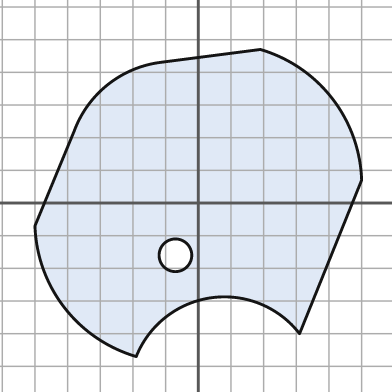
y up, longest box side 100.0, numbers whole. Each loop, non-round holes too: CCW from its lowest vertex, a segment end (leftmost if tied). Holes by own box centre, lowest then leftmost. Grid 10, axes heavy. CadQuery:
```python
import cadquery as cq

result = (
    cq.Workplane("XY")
    .moveTo(-19.0, -47.0)
    .threePointArc((4.0, -29.0), (31.0, -40.0))
    .lineTo(50.0, 7.0)
    .threePointArc((41.0, 32.0), (19.0, 47.0))
    .lineTo(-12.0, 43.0)
    .threePointArc((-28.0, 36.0), (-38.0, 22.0))
    .lineTo(-50.0, -7.0)
    .threePointArc((-41.0, -32.0), (-19.0, -47.0))
    .close()
    .moveTo(-7.0, -16.0)
    .circle(5.0)
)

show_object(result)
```